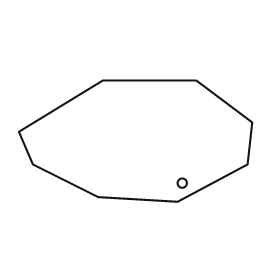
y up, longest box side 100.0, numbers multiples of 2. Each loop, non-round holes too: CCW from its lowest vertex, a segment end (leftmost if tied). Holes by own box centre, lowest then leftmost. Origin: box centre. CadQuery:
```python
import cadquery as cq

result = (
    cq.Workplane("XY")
    .moveTo(18.0, -26.0)
    .lineTo(48.0, -10.0)
    .lineTo(50.0, 8.0)
    .lineTo(26.0, 26.0)
    .lineTo(-14.0, 26.0)
    .lineTo(-50.0, 4.0)
    .lineTo(-44.0, -10.0)
    .lineTo(-16.0, -24.0)
    .close()
    .moveTo(20.0, -18.0)
    .circle(2.0)
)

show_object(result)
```